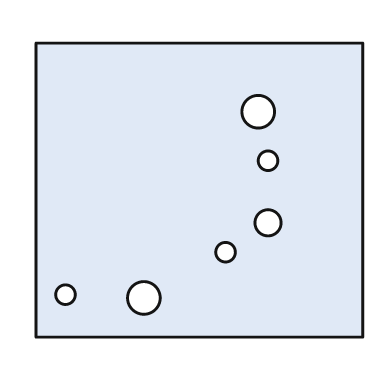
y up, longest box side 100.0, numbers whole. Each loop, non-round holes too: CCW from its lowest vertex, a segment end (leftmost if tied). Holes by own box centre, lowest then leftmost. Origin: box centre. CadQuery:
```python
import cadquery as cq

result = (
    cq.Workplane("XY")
    .moveTo(-50.0, -45.0)
    .lineTo(50.0, -45.0)
    .lineTo(50.0, 45.0)
    .lineTo(-50.0, 45.0)
    .close()
    .moveTo(-17.0, -33.0)
    .circle(5.0)
    .moveTo(-41.0, -32.0)
    .circle(3.0)
    .moveTo(8.0, -19.0)
    .circle(3.0)
    .moveTo(21.0, -10.0)
    .circle(4.0)
    .moveTo(21.0, 9.0)
    .circle(3.0)
    .moveTo(18.0, 24.0)
    .circle(5.0)
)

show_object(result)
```